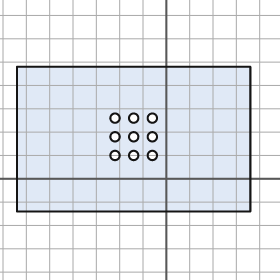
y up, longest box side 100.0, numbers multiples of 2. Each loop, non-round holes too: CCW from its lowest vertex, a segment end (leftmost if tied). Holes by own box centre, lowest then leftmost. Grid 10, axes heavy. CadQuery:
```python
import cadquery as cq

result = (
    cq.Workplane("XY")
    .moveTo(-64.0, -14.0)
    .lineTo(36.0, -14.0)
    .lineTo(36.0, 48.0)
    .lineTo(-64.0, 48.0)
    .close()
    .moveTo(-22.0, 10.0)
    .circle(2.0)
    .moveTo(-14.0, 10.0)
    .circle(2.0)
    .moveTo(-6.0, 10.0)
    .circle(2.0)
    .moveTo(-22.0, 18.0)
    .circle(2.0)
    .moveTo(-14.0, 18.0)
    .circle(2.0)
    .moveTo(-6.0, 18.0)
    .circle(2.0)
    .moveTo(-22.0, 26.0)
    .circle(2.0)
    .moveTo(-14.0, 26.0)
    .circle(2.0)
    .moveTo(-6.0, 26.0)
    .circle(2.0)
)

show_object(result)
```